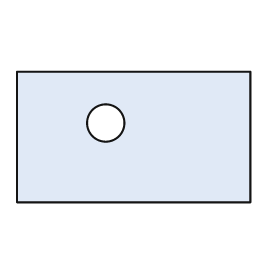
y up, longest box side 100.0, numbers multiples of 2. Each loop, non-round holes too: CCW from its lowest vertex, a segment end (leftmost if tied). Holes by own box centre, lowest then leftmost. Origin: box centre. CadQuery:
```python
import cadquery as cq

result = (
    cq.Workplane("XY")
    .moveTo(-50.0, -28.0)
    .lineTo(50.0, -28.0)
    .lineTo(50.0, 28.0)
    .lineTo(-50.0, 28.0)
    .close()
    .moveTo(-12.0, 6.0)
    .circle(8.0)
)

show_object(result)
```